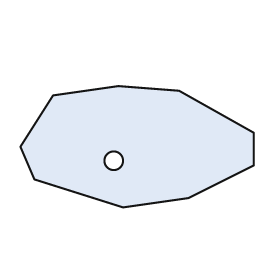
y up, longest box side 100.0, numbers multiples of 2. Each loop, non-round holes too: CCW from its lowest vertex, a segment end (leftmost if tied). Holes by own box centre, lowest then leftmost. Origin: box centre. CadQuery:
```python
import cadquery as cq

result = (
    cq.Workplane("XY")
    .moveTo(-6.0, -26.0)
    .lineTo(22.0, -22.0)
    .lineTo(50.0, -8.0)
    .lineTo(50.0, 6.0)
    .lineTo(18.0, 24.0)
    .lineTo(-8.0, 26.0)
    .lineTo(-36.0, 22.0)
    .lineTo(-50.0, 0.0)
    .lineTo(-44.0, -14.0)
    .close()
    .moveTo(-10.0, -6.0)
    .circle(4.0)
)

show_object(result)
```